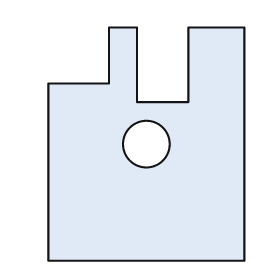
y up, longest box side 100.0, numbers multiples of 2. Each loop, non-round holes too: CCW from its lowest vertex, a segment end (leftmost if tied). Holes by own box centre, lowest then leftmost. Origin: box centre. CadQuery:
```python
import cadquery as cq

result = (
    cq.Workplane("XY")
    .moveTo(-42.0, -50.0)
    .lineTo(42.0, -50.0)
    .lineTo(42.0, 50.0)
    .lineTo(18.0, 50.0)
    .lineTo(18.0, 18.0)
    .lineTo(-4.0, 18.0)
    .lineTo(-4.0, 50.0)
    .lineTo(-16.0, 50.0)
    .lineTo(-16.0, 26.0)
    .lineTo(-42.0, 26.0)
    .close()
    .moveTo(0.0, 0.0)
    .circle(10.0)
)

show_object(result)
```